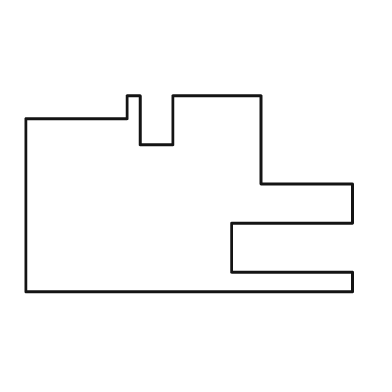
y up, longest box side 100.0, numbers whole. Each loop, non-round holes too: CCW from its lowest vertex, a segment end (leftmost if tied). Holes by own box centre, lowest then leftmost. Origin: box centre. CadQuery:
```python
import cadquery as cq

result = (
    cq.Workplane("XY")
    .moveTo(-50.0, -30.0)
    .lineTo(50.0, -30.0)
    .lineTo(50.0, -24.0)
    .lineTo(13.0, -24.0)
    .lineTo(13.0, -9.0)
    .lineTo(50.0, -9.0)
    .lineTo(50.0, 3.0)
    .lineTo(22.0, 3.0)
    .lineTo(22.0, 30.0)
    .lineTo(-5.0, 30.0)
    .lineTo(-5.0, 15.0)
    .lineTo(-15.0, 15.0)
    .lineTo(-15.0, 30.0)
    .lineTo(-19.0, 30.0)
    .lineTo(-19.0, 23.0)
    .lineTo(-50.0, 23.0)
    .close()
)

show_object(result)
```